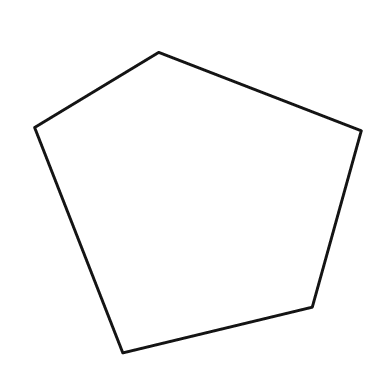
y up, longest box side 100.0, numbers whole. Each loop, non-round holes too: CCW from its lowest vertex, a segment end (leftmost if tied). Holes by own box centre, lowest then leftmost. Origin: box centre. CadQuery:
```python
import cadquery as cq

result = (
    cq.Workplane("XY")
    .moveTo(-23.0, -46.0)
    .lineTo(35.0, -32.0)
    .lineTo(50.0, 22.0)
    .lineTo(-12.0, 46.0)
    .lineTo(-50.0, 23.0)
    .close()
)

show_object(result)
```